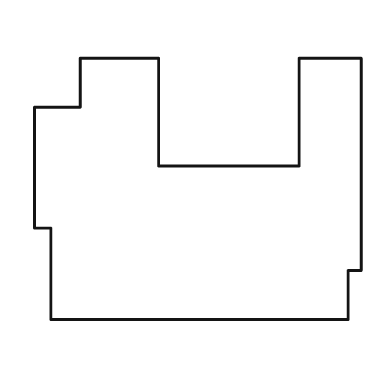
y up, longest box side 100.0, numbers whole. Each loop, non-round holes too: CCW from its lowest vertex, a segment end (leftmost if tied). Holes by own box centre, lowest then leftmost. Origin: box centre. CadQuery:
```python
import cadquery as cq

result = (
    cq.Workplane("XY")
    .moveTo(-45.0, -40.0)
    .lineTo(46.0, -40.0)
    .lineTo(46.0, -25.0)
    .lineTo(50.0, -25.0)
    .lineTo(50.0, 40.0)
    .lineTo(31.0, 40.0)
    .lineTo(31.0, 7.0)
    .lineTo(-12.0, 7.0)
    .lineTo(-12.0, 40.0)
    .lineTo(-36.0, 40.0)
    .lineTo(-36.0, 25.0)
    .lineTo(-50.0, 25.0)
    .lineTo(-50.0, -12.0)
    .lineTo(-45.0, -12.0)
    .close()
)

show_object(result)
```